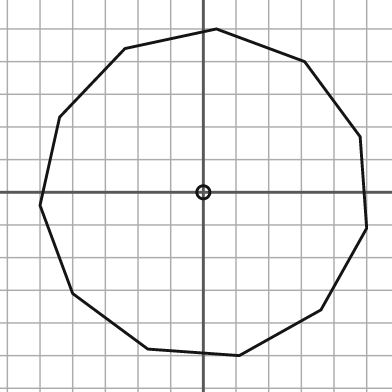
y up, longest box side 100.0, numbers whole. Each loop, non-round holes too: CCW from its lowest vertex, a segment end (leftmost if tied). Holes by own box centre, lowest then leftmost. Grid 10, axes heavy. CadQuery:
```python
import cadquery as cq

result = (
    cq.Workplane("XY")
    .moveTo(11.0, -50.0)
    .lineTo(36.0, -36.0)
    .lineTo(50.0, -11.0)
    .lineTo(48.0, 17.0)
    .lineTo(31.0, 40.0)
    .lineTo(4.0, 50.0)
    .lineTo(-24.0, 44.0)
    .lineTo(-44.0, 23.0)
    .lineTo(-50.0, -4.0)
    .lineTo(-40.0, -31.0)
    .lineTo(-17.0, -48.0)
    .close()
    .moveTo(0.0, 0.0)
    .circle(2.0)
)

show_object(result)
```